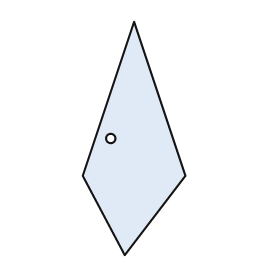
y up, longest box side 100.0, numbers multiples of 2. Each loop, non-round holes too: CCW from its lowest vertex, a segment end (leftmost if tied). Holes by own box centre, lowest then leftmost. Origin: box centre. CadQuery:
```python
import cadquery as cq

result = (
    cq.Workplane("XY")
    .moveTo(-4.0, -50.0)
    .lineTo(22.0, -16.0)
    .lineTo(0.0, 50.0)
    .lineTo(-22.0, -16.0)
    .close()
    .moveTo(-10.0, 0.0)
    .circle(2.0)
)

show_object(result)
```